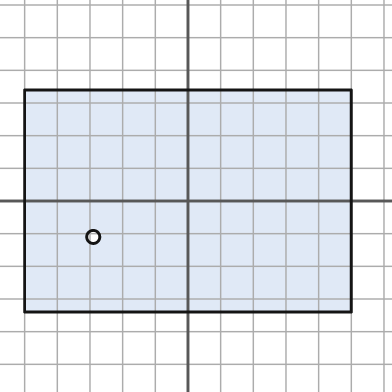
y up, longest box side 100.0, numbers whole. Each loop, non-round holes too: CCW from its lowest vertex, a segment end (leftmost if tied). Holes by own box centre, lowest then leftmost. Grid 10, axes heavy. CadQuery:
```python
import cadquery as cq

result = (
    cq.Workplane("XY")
    .moveTo(-50.0, -34.0)
    .lineTo(50.0, -34.0)
    .lineTo(50.0, 34.0)
    .lineTo(-50.0, 34.0)
    .close()
    .moveTo(-29.0, -11.0)
    .circle(2.0)
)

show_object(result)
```